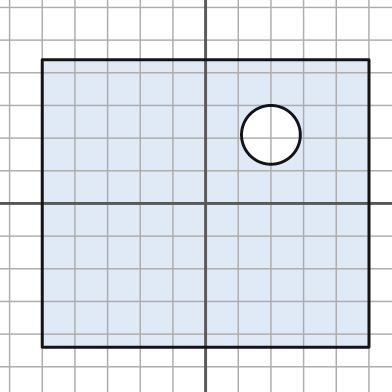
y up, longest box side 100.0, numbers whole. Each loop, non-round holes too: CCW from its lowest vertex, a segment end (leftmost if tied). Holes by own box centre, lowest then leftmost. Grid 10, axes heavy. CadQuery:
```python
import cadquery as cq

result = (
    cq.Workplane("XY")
    .moveTo(-50.0, -44.0)
    .lineTo(50.0, -44.0)
    .lineTo(50.0, 44.0)
    .lineTo(-50.0, 44.0)
    .close()
    .moveTo(20.0, 21.0)
    .circle(9.0)
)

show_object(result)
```